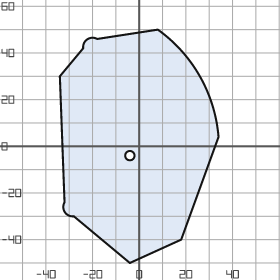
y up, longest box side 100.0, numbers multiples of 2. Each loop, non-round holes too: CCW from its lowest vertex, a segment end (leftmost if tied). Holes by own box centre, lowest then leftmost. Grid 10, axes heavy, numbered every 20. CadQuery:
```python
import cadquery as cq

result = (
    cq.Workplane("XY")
    .moveTo(-4.0, -50.0)
    .lineTo(18.0, -40.0)
    .lineTo(34.0, 4.0)
    .threePointArc((26.0, 30.0), (8.0, 50.0))
    .lineTo(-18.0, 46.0)
    .threePointArc((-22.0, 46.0), (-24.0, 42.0))
    .lineTo(-34.0, 30.0)
    .lineTo(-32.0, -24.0)
    .threePointArc((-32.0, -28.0), (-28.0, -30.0))
    .close()
    .moveTo(-4.0, -4.0)
    .circle(2.0)
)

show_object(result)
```